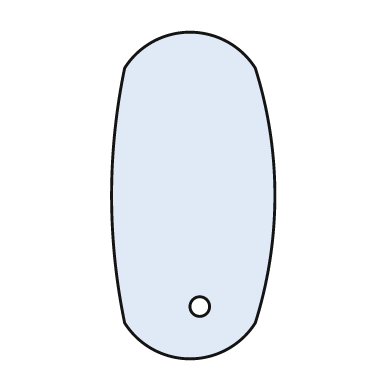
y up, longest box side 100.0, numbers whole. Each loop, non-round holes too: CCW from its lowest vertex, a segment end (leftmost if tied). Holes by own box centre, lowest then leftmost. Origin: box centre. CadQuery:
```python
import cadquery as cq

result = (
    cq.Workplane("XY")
    .moveTo(-21.0, -39.0)
    .threePointArc((-1.0, -50.0), (19.0, -39.0))
    .threePointArc((25.0, 0.0), (19.0, 39.0))
    .threePointArc((-1.0, 50.0), (-21.0, 39.0))
    .threePointArc((-25.0, 0.0), (-21.0, -39.0))
    .close()
    .moveTo(2.0, -34.0)
    .circle(3.0)
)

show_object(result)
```